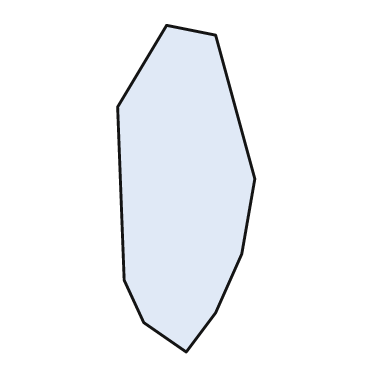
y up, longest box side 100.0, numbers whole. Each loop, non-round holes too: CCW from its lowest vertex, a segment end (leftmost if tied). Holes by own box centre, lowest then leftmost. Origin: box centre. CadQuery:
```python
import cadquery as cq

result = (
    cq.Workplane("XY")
    .moveTo(0.0, -50.0)
    .lineTo(9.0, -38.0)
    .lineTo(17.0, -20.0)
    .lineTo(21.0, 3.0)
    .lineTo(9.0, 47.0)
    .lineTo(-6.0, 50.0)
    .lineTo(-21.0, 25.0)
    .lineTo(-19.0, -28.0)
    .lineTo(-13.0, -41.0)
    .close()
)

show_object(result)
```